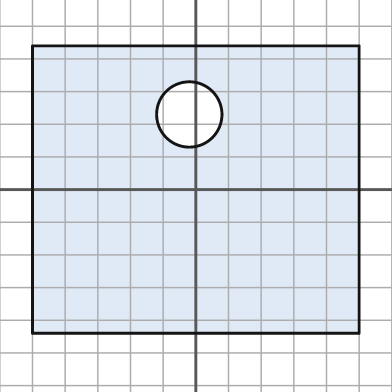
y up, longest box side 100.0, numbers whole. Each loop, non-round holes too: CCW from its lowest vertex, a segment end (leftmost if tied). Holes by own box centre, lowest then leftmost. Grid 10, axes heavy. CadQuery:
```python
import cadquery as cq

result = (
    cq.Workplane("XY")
    .moveTo(-50.0, -44.0)
    .lineTo(50.0, -44.0)
    .lineTo(50.0, 44.0)
    .lineTo(-50.0, 44.0)
    .close()
    .moveTo(-2.0, 23.0)
    .circle(10.0)
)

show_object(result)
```